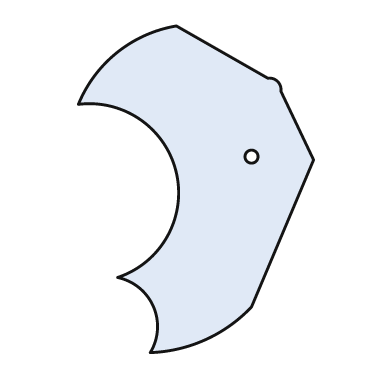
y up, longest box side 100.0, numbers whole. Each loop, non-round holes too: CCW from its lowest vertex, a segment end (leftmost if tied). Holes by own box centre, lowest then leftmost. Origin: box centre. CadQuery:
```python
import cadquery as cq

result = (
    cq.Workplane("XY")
    .moveTo(-14.0, -50.0)
    .threePointArc((3.0, -46.0), (17.0, -36.0))
    .lineTo(36.0, 9.0)
    .lineTo(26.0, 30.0)
    .threePointArc((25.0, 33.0), (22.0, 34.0))
    .lineTo(-6.0, 50.0)
    .threePointArc((-24.0, 42.0), (-36.0, 26.0))
    .threePointArc((-6.0, 5.0), (-24.0, -27.0))
    .threePointArc((-13.0, -36.0), (-14.0, -50.0))
    .close()
    .moveTo(17.0, 10.0)
    .circle(2.0)
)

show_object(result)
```